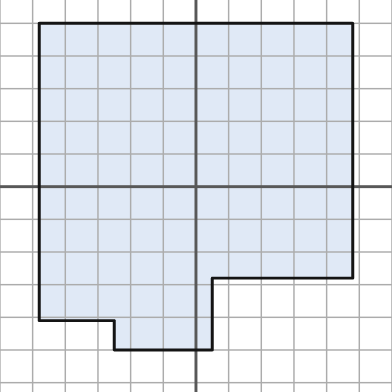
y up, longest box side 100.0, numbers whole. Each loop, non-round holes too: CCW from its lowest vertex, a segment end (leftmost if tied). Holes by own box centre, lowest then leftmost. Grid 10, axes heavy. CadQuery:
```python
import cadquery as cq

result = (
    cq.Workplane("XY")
    .moveTo(-25.0, -50.0)
    .lineTo(5.0, -50.0)
    .lineTo(5.0, -28.0)
    .lineTo(48.0, -28.0)
    .lineTo(48.0, 50.0)
    .lineTo(-48.0, 50.0)
    .lineTo(-48.0, -41.0)
    .lineTo(-25.0, -41.0)
    .close()
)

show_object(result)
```